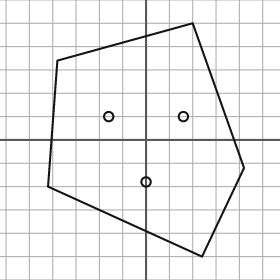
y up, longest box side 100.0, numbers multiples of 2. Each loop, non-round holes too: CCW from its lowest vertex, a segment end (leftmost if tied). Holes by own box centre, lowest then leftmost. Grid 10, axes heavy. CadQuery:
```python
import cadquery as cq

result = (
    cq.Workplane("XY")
    .moveTo(24.0, -50.0)
    .lineTo(42.0, -12.0)
    .lineTo(20.0, 50.0)
    .lineTo(-38.0, 34.0)
    .lineTo(-42.0, -20.0)
    .close()
    .moveTo(0.0, -18.0)
    .circle(2.0)
    .moveTo(-16.0, 10.0)
    .circle(2.0)
    .moveTo(16.0, 10.0)
    .circle(2.0)
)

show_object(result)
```